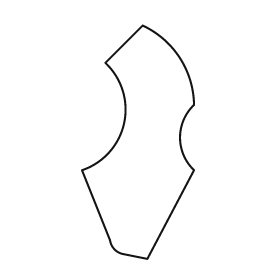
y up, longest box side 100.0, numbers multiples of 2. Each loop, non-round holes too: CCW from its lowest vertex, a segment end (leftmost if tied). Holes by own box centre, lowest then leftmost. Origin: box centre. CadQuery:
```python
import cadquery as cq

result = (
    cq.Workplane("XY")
    .moveTo(4.0, -50.0)
    .lineTo(24.0, -12.0)
    .threePointArc((18.0, 2.0), (24.0, 16.0))
    .threePointArc((18.0, 36.0), (2.0, 50.0))
    .lineTo(-14.0, 34.0)
    .threePointArc((-6.0, 8.0), (-24.0, -12.0))
    .lineTo(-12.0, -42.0)
    .threePointArc((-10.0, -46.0), (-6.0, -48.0))
    .close()
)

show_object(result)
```